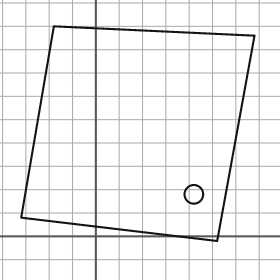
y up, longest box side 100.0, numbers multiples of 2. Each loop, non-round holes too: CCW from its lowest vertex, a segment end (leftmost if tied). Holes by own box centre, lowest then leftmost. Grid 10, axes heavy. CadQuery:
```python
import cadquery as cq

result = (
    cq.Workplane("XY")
    .moveTo(52.0, -2.0)
    .lineTo(68.0, 86.0)
    .lineTo(-18.0, 90.0)
    .lineTo(-32.0, 8.0)
    .close()
    .moveTo(42.0, 18.0)
    .circle(4.0)
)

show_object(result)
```